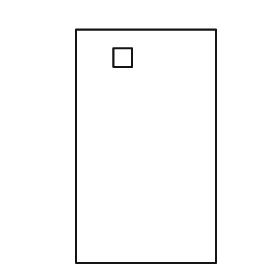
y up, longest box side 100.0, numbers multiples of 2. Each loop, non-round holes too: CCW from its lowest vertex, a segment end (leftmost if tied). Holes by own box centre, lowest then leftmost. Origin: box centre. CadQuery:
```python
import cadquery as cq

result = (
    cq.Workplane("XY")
    .moveTo(-30.0, -50.0)
    .lineTo(30.0, -50.0)
    .lineTo(30.0, 50.0)
    .lineTo(-30.0, 50.0)
    .close()
    .moveTo(-14.0, 34.0)
    .lineTo(-6.0, 34.0)
    .lineTo(-6.0, 42.0)
    .lineTo(-14.0, 42.0)
    .close()
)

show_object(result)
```